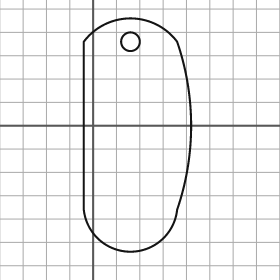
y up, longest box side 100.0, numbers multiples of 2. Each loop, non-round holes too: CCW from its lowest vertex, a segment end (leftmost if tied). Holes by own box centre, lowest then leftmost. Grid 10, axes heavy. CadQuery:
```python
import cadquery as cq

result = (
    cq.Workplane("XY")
    .moveTo(-4.0, -36.0)
    .threePointArc((16.0, -54.0), (36.0, -36.0))
    .threePointArc((42.0, 0.0), (36.0, 36.0))
    .threePointArc((16.0, 46.0), (-4.0, 36.0))
    .close()
    .moveTo(16.0, 36.0)
    .circle(4.0)
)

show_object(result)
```